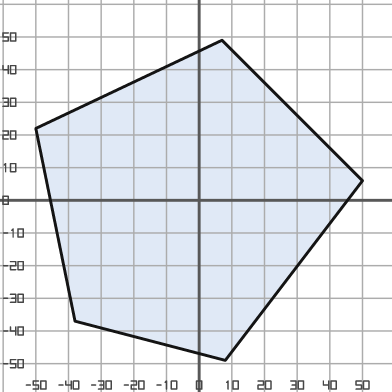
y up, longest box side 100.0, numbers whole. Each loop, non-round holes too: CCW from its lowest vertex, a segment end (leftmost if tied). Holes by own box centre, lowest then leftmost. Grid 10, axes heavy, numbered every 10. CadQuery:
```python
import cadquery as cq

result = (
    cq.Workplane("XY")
    .moveTo(8.0, -49.0)
    .lineTo(50.0, 6.0)
    .lineTo(7.0, 49.0)
    .lineTo(-50.0, 22.0)
    .lineTo(-38.0, -37.0)
    .close()
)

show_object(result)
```